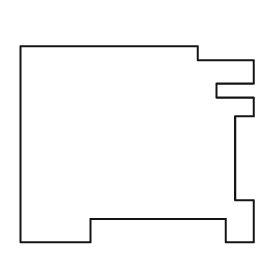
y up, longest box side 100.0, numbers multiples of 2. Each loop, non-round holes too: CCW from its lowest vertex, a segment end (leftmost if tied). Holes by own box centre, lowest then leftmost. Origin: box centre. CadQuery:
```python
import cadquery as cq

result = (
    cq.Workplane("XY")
    .moveTo(-50.0, -42.0)
    .lineTo(-20.0, -42.0)
    .lineTo(-20.0, -32.0)
    .lineTo(38.0, -32.0)
    .lineTo(38.0, -42.0)
    .lineTo(50.0, -42.0)
    .lineTo(50.0, -24.0)
    .lineTo(42.0, -24.0)
    .lineTo(42.0, 12.0)
    .lineTo(50.0, 12.0)
    .lineTo(50.0, 20.0)
    .lineTo(34.0, 20.0)
    .lineTo(34.0, 26.0)
    .lineTo(50.0, 26.0)
    .lineTo(50.0, 36.0)
    .lineTo(26.0, 36.0)
    .lineTo(26.0, 42.0)
    .lineTo(-50.0, 42.0)
    .close()
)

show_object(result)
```